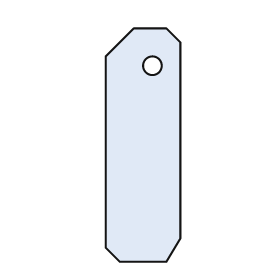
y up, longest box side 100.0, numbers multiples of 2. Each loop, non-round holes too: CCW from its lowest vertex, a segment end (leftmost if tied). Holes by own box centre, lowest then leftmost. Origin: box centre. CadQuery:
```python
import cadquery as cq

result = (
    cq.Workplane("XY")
    .moveTo(-10.0, -50.0)
    .lineTo(10.0, -50.0)
    .lineTo(16.0, -40.0)
    .lineTo(16.0, 44.0)
    .lineTo(10.0, 50.0)
    .lineTo(-4.0, 50.0)
    .lineTo(-16.0, 38.0)
    .lineTo(-16.0, -44.0)
    .close()
    .moveTo(4.0, 34.0)
    .circle(4.0)
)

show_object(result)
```